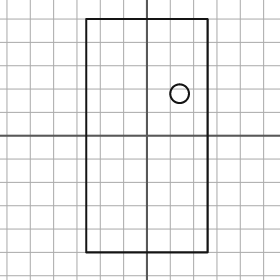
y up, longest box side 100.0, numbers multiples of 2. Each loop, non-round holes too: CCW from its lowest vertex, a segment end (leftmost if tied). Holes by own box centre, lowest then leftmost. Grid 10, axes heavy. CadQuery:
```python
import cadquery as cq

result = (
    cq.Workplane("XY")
    .moveTo(-26.0, -50.0)
    .lineTo(26.0, -50.0)
    .lineTo(26.0, 50.0)
    .lineTo(-26.0, 50.0)
    .close()
    .moveTo(14.0, 18.0)
    .circle(4.0)
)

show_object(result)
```